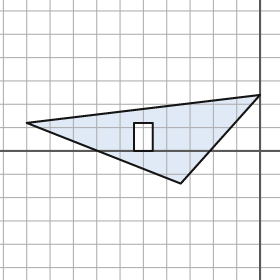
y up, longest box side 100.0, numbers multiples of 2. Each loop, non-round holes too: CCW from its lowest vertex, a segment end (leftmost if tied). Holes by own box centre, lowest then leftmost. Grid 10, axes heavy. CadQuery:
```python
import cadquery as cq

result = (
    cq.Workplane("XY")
    .moveTo(-34.0, -14.0)
    .lineTo(0.0, 24.0)
    .lineTo(-100.0, 12.0)
    .close()
    .moveTo(-54.0, 0.0)
    .lineTo(-46.0, 0.0)
    .lineTo(-46.0, 12.0)
    .lineTo(-54.0, 12.0)
    .close()
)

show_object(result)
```